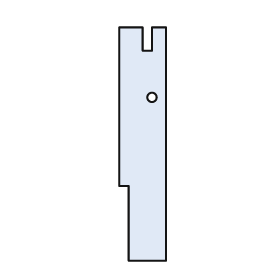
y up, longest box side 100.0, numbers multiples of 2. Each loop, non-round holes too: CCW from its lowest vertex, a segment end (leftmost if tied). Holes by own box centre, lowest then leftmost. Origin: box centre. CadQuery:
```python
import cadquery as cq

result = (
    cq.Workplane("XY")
    .moveTo(-6.0, -50.0)
    .lineTo(10.0, -50.0)
    .lineTo(10.0, 50.0)
    .lineTo(4.0, 50.0)
    .lineTo(4.0, 40.0)
    .lineTo(0.0, 40.0)
    .lineTo(0.0, 50.0)
    .lineTo(-10.0, 50.0)
    .lineTo(-10.0, -18.0)
    .lineTo(-6.0, -18.0)
    .close()
    .moveTo(4.0, 20.0)
    .circle(2.0)
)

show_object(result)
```